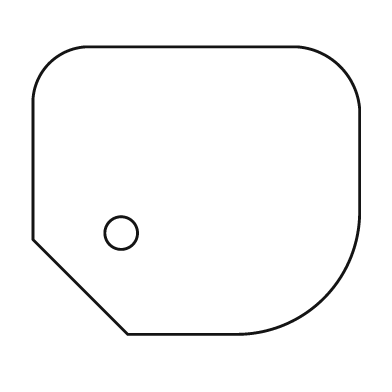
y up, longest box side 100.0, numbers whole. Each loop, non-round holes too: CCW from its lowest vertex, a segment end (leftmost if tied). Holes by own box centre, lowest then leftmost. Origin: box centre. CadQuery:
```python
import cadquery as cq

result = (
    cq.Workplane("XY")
    .moveTo(-21.0, -44.0)
    .lineTo(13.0, -44.0)
    .threePointArc((39.0, -33.0), (50.0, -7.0))
    .lineTo(50.0, 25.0)
    .threePointArc((44.0, 38.0), (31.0, 44.0))
    .lineTo(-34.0, 44.0)
    .threePointArc((-45.0, 39.0), (-50.0, 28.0))
    .lineTo(-50.0, -15.0)
    .close()
    .moveTo(-23.0, -13.0)
    .circle(5.0)
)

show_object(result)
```